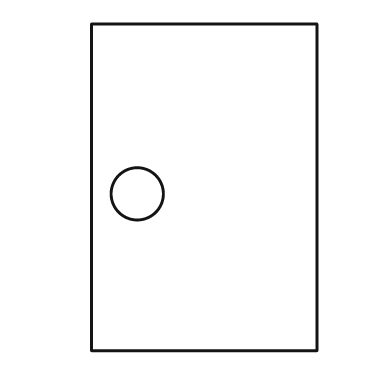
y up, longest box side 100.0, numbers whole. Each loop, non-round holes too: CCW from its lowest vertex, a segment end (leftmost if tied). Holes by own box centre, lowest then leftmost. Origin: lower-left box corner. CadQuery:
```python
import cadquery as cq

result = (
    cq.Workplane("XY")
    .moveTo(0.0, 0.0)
    .lineTo(69.0, 0.0)
    .lineTo(69.0, 100.0)
    .lineTo(0.0, 100.0)
    .close()
    .moveTo(14.0, 48.0)
    .circle(8.0)
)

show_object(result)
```